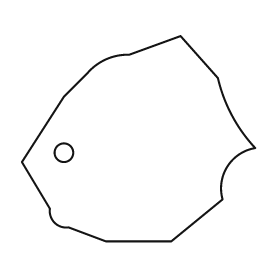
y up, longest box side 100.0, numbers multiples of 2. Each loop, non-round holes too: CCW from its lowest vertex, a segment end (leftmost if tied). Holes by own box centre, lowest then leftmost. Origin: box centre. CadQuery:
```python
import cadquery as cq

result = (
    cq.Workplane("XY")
    .moveTo(-14.0, -44.0)
    .lineTo(14.0, -44.0)
    .lineTo(36.0, -26.0)
    .threePointArc((38.0, -12.0), (50.0, -4.0))
    .threePointArc((40.0, 10.0), (34.0, 26.0))
    .lineTo(18.0, 44.0)
    .lineTo(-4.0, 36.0)
    .threePointArc((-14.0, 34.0), (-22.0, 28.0))
    .lineTo(-32.0, 18.0)
    .lineTo(-50.0, -10.0)
    .lineTo(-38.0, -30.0)
    .threePointArc((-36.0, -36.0), (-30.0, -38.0))
    .close()
    .moveTo(-32.0, -6.0)
    .circle(4.0)
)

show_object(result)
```